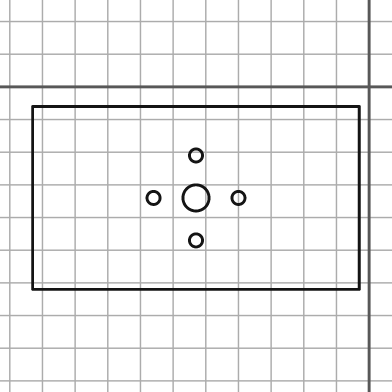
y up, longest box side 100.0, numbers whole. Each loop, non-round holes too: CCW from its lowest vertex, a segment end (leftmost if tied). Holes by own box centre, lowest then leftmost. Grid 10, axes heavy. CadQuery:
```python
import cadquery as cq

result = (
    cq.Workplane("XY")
    .moveTo(-103.0, -62.0)
    .lineTo(-3.0, -62.0)
    .lineTo(-3.0, -6.0)
    .lineTo(-103.0, -6.0)
    .close()
    .moveTo(-53.0, -47.0)
    .circle(2.0)
    .moveTo(-66.0, -34.0)
    .circle(2.0)
    .moveTo(-53.0, -34.0)
    .circle(4.0)
    .moveTo(-40.0, -34.0)
    .circle(2.0)
    .moveTo(-53.0, -21.0)
    .circle(2.0)
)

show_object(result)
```